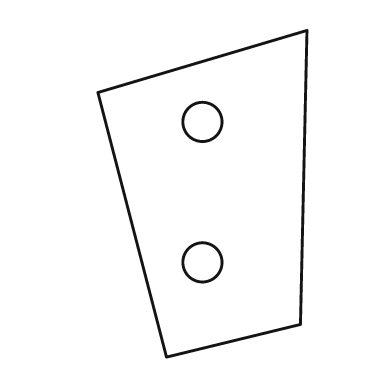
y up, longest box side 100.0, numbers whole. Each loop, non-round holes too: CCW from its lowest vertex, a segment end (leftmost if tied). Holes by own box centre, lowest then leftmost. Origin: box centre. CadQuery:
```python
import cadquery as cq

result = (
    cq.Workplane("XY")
    .moveTo(-11.0, -50.0)
    .lineTo(30.0, -40.0)
    .lineTo(32.0, 50.0)
    .lineTo(-32.0, 31.0)
    .close()
    .moveTo(0.0, -21.0)
    .circle(6.0)
    .moveTo(0.0, 22.0)
    .circle(6.0)
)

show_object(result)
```